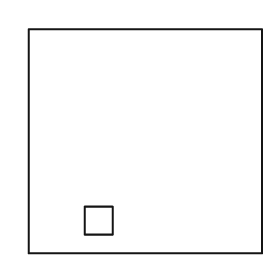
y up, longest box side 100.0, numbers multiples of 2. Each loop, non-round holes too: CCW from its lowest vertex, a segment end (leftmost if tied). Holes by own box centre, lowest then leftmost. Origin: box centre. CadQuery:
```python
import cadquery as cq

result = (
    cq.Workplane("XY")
    .moveTo(-50.0, -48.0)
    .lineTo(50.0, -48.0)
    .lineTo(50.0, 48.0)
    .lineTo(-50.0, 48.0)
    .close()
    .moveTo(-26.0, -40.0)
    .lineTo(-14.0, -40.0)
    .lineTo(-14.0, -28.0)
    .lineTo(-26.0, -28.0)
    .close()
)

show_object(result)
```